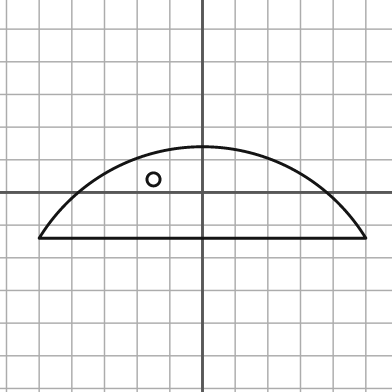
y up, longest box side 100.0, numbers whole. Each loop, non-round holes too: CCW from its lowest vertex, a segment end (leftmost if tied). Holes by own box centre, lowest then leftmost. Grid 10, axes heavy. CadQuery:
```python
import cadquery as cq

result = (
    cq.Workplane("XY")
    .moveTo(-50.0, -14.0)
    .lineTo(50.0, -14.0)
    .threePointArc((0.0, 14.0), (-50.0, -14.0))
    .close()
    .moveTo(-15.0, 4.0)
    .circle(2.0)
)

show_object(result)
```